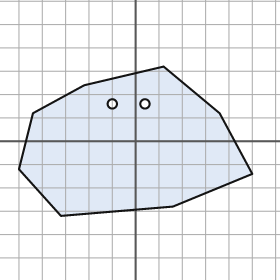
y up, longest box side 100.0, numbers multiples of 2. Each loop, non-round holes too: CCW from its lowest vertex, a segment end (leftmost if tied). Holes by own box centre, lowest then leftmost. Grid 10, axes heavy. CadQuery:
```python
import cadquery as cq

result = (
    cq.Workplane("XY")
    .moveTo(-32.0, -32.0)
    .lineTo(16.0, -28.0)
    .lineTo(50.0, -14.0)
    .lineTo(36.0, 12.0)
    .lineTo(12.0, 32.0)
    .lineTo(-22.0, 24.0)
    .lineTo(-44.0, 12.0)
    .lineTo(-50.0, -12.0)
    .close()
    .moveTo(-10.0, 16.0)
    .circle(2.0)
    .moveTo(4.0, 16.0)
    .circle(2.0)
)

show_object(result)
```